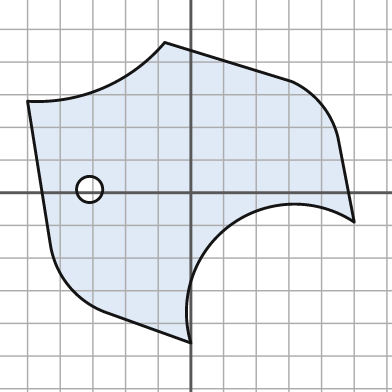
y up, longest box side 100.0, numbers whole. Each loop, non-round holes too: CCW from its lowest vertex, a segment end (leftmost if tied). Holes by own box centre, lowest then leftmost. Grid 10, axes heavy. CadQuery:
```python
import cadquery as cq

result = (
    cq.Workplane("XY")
    .moveTo(0.0, -46.0)
    .threePointArc((12.0, -10.0), (50.0, -9.0))
    .lineTo(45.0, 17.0)
    .threePointArc((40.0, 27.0), (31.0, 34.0))
    .lineTo(-8.0, 46.0)
    .threePointArc((-27.0, 32.0), (-50.0, 28.0))
    .lineTo(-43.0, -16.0)
    .threePointArc((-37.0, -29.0), (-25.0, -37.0))
    .close()
    .moveTo(-31.0, 1.0)
    .circle(4.0)
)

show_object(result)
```